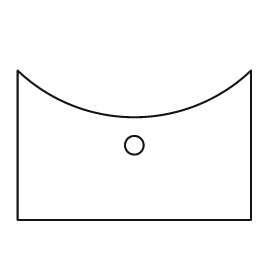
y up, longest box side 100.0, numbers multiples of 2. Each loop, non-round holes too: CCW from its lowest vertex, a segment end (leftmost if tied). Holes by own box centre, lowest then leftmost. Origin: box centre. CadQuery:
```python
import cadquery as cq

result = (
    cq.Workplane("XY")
    .moveTo(-50.0, -32.0)
    .lineTo(50.0, -32.0)
    .lineTo(50.0, 32.0)
    .threePointArc((0.0, 12.0), (-50.0, 32.0))
    .close()
    .moveTo(0.0, 0.0)
    .circle(4.0)
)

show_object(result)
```